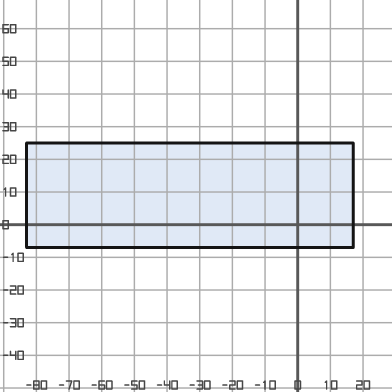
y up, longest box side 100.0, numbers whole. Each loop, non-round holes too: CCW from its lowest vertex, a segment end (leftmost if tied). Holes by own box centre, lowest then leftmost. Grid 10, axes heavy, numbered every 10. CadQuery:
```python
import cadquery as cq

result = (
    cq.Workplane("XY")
    .moveTo(-83.0, -7.0)
    .lineTo(17.0, -7.0)
    .lineTo(17.0, 25.0)
    .lineTo(-83.0, 25.0)
    .close()
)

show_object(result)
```